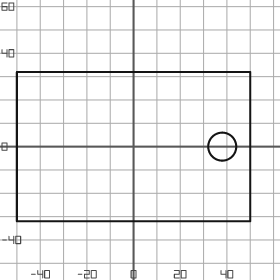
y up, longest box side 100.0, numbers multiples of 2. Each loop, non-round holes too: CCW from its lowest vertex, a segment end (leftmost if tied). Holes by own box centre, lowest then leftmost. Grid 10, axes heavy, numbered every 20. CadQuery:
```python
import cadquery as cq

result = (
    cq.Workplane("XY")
    .moveTo(-50.0, -32.0)
    .lineTo(50.0, -32.0)
    .lineTo(50.0, 32.0)
    .lineTo(-50.0, 32.0)
    .close()
    .moveTo(38.0, 0.0)
    .circle(6.0)
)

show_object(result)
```